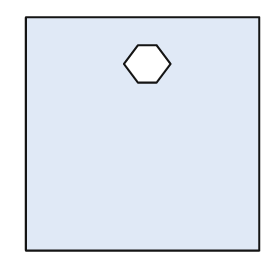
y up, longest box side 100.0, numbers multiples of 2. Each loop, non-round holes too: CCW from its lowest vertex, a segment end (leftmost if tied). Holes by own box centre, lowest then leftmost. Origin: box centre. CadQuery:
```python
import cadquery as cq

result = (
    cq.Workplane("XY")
    .moveTo(-50.0, -50.0)
    .lineTo(50.0, -50.0)
    .lineTo(50.0, 50.0)
    .lineTo(-50.0, 50.0)
    .close()
    .moveTo(-2.0, 22.0)
    .lineTo(6.0, 22.0)
    .lineTo(12.0, 30.0)
    .lineTo(6.0, 38.0)
    .lineTo(-2.0, 38.0)
    .lineTo(-8.0, 30.0)
    .close()
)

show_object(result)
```